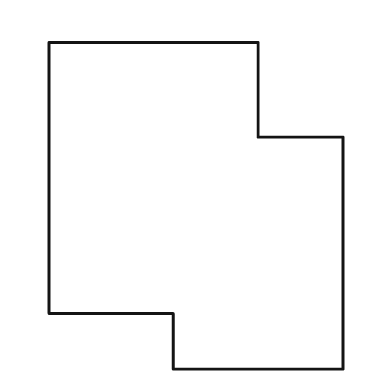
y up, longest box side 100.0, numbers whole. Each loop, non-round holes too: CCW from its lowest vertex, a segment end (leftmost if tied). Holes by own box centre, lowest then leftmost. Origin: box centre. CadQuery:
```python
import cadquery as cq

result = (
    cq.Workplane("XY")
    .moveTo(-7.0, -50.0)
    .lineTo(45.0, -50.0)
    .lineTo(45.0, 21.0)
    .lineTo(19.0, 21.0)
    .lineTo(19.0, 50.0)
    .lineTo(-45.0, 50.0)
    .lineTo(-45.0, -33.0)
    .lineTo(-7.0, -33.0)
    .close()
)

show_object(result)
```